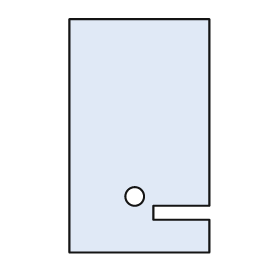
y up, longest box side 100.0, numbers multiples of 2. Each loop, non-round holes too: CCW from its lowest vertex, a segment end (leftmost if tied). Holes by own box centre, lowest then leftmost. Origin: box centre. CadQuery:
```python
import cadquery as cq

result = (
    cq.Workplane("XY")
    .moveTo(-30.0, -50.0)
    .lineTo(30.0, -50.0)
    .lineTo(30.0, -36.0)
    .lineTo(6.0, -36.0)
    .lineTo(6.0, -30.0)
    .lineTo(30.0, -30.0)
    .lineTo(30.0, 50.0)
    .lineTo(-30.0, 50.0)
    .close()
    .moveTo(-2.0, -26.0)
    .circle(4.0)
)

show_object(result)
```